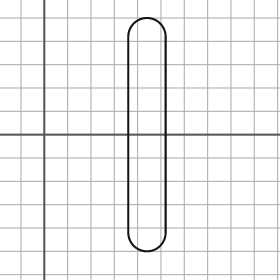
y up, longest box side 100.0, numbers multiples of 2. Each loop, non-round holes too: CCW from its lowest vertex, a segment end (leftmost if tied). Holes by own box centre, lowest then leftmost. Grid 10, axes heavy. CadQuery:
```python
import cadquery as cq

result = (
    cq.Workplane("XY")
    .moveTo(36.0, -42.0)
    .threePointArc((44.0, -50.0), (52.0, -42.0))
    .lineTo(52.0, 42.0)
    .threePointArc((44.0, 50.0), (36.0, 42.0))
    .close()
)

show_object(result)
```